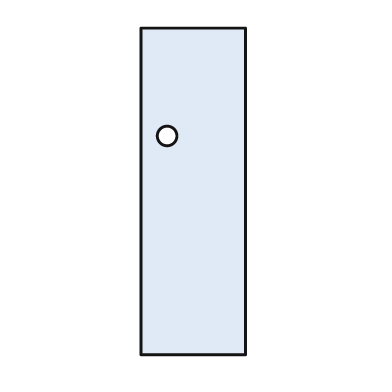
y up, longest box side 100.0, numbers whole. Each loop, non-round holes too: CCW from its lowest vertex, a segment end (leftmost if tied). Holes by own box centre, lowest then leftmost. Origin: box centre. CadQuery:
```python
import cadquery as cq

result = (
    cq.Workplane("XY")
    .moveTo(-16.0, -50.0)
    .lineTo(16.0, -50.0)
    .lineTo(16.0, 50.0)
    .lineTo(-16.0, 50.0)
    .close()
    .moveTo(-8.0, 17.0)
    .circle(3.0)
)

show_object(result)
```